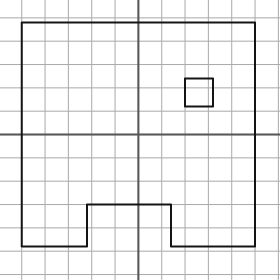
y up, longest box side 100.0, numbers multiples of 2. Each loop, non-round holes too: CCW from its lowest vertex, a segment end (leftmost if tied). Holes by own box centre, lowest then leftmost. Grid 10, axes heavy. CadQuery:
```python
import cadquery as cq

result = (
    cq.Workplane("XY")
    .moveTo(-50.0, -48.0)
    .lineTo(-22.0, -48.0)
    .lineTo(-22.0, -30.0)
    .lineTo(14.0, -30.0)
    .lineTo(14.0, -48.0)
    .lineTo(50.0, -48.0)
    .lineTo(50.0, 48.0)
    .lineTo(-50.0, 48.0)
    .close()
    .moveTo(20.0, 12.0)
    .lineTo(32.0, 12.0)
    .lineTo(32.0, 24.0)
    .lineTo(20.0, 24.0)
    .close()
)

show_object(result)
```